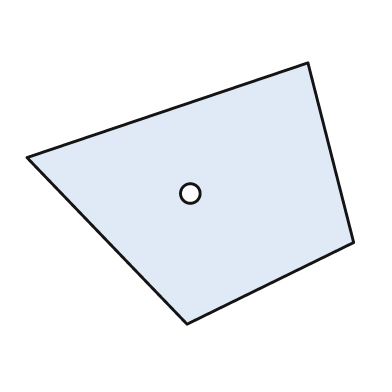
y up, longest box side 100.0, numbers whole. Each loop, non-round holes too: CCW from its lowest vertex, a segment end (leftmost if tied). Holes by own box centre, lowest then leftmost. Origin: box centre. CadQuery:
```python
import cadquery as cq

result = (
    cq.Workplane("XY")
    .moveTo(-1.0, -40.0)
    .lineTo(50.0, -15.0)
    .lineTo(36.0, 40.0)
    .lineTo(-50.0, 11.0)
    .close()
    .moveTo(0.0, 0.0)
    .circle(3.0)
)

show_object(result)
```